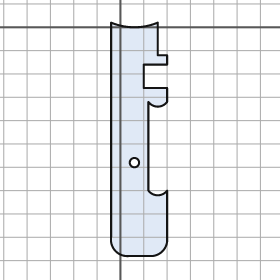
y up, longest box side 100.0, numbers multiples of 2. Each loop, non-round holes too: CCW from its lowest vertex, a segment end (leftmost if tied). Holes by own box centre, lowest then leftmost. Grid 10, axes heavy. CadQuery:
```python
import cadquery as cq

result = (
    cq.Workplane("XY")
    .moveTo(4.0, -98.0)
    .lineTo(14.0, -98.0)
    .threePointArc((18.0, -96.0), (20.0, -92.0))
    .lineTo(20.0, -70.0)
    .threePointArc((16.0, -72.0), (12.0, -70.0))
    .lineTo(12.0, -32.0)
    .threePointArc((16.0, -34.0), (20.0, -32.0))
    .lineTo(20.0, -26.0)
    .lineTo(10.0, -26.0)
    .lineTo(10.0, -16.0)
    .lineTo(20.0, -16.0)
    .lineTo(20.0, -12.0)
    .lineTo(16.0, -12.0)
    .lineTo(16.0, 2.0)
    .threePointArc((6.0, 0.0), (-4.0, 2.0))
    .lineTo(-4.0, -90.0)
    .threePointArc((-2.0, -96.0), (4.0, -98.0))
    .close()
    .moveTo(6.0, -58.0)
    .circle(2.0)
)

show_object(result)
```